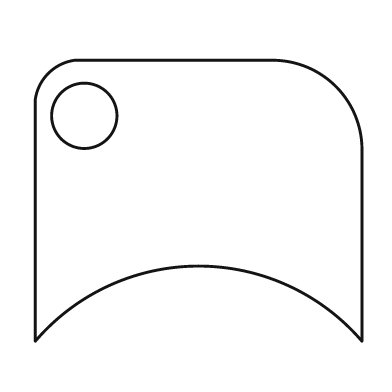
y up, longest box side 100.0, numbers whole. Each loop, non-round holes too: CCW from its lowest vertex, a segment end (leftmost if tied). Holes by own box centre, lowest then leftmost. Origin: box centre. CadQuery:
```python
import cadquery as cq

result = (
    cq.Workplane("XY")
    .moveTo(-50.0, -43.0)
    .threePointArc((0.0, -20.0), (50.0, -43.0))
    .lineTo(50.0, 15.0)
    .threePointArc((42.0, 35.0), (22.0, 43.0))
    .lineTo(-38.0, 43.0)
    .threePointArc((-46.0, 39.0), (-50.0, 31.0))
    .close()
    .moveTo(-35.0, 26.0)
    .circle(10.0)
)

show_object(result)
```